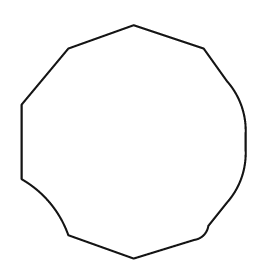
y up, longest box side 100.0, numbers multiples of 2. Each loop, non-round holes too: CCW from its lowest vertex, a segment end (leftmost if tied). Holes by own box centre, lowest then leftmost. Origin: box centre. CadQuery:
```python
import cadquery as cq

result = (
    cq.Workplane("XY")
    .moveTo(0.0, -50.0)
    .lineTo(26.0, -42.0)
    .threePointArc((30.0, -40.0), (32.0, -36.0))
    .lineTo(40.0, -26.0)
    .threePointArc((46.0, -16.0), (48.0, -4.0))
    .lineTo(48.0, 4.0)
    .threePointArc((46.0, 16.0), (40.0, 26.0))
    .lineTo(30.0, 40.0)
    .lineTo(0.0, 50.0)
    .lineTo(-28.0, 40.0)
    .lineTo(-48.0, 16.0)
    .lineTo(-48.0, -16.0)
    .threePointArc((-36.0, -26.0), (-28.0, -40.0))
    .close()
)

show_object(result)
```